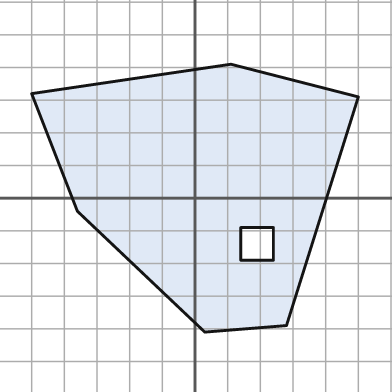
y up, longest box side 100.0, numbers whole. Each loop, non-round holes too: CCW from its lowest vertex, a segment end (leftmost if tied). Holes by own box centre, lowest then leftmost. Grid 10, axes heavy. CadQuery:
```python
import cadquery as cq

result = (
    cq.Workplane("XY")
    .moveTo(3.0, -41.0)
    .lineTo(28.0, -39.0)
    .lineTo(50.0, 31.0)
    .lineTo(11.0, 41.0)
    .lineTo(-50.0, 32.0)
    .lineTo(-36.0, -4.0)
    .close()
    .moveTo(14.0, -19.0)
    .lineTo(24.0, -19.0)
    .lineTo(24.0, -9.0)
    .lineTo(14.0, -9.0)
    .close()
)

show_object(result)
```